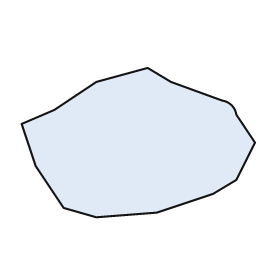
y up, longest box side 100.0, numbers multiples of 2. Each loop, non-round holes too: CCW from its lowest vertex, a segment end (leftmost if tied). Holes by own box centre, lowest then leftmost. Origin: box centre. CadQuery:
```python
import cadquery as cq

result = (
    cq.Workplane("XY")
    .moveTo(-18.0, -32.0)
    .lineTo(8.0, -30.0)
    .lineTo(32.0, -22.0)
    .lineTo(42.0, -16.0)
    .lineTo(50.0, 0.0)
    .lineTo(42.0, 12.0)
    .threePointArc((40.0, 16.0), (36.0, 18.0))
    .lineTo(14.0, 26.0)
    .lineTo(4.0, 32.0)
    .lineTo(-18.0, 26.0)
    .lineTo(-36.0, 14.0)
    .lineTo(-50.0, 8.0)
    .lineTo(-44.0, -10.0)
    .lineTo(-32.0, -28.0)
    .close()
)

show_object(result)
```